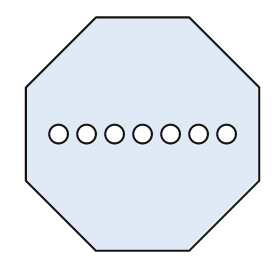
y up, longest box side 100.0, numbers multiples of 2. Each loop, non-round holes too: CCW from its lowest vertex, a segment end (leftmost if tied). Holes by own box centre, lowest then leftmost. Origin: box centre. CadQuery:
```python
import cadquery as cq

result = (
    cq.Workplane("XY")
    .moveTo(-20.0, -50.0)
    .lineTo(20.0, -50.0)
    .lineTo(50.0, -20.0)
    .lineTo(50.0, 20.0)
    .lineTo(20.0, 50.0)
    .lineTo(-20.0, 50.0)
    .lineTo(-50.0, 20.0)
    .lineTo(-50.0, -20.0)
    .close()
    .moveTo(-36.0, 0.0)
    .circle(4.0)
    .moveTo(-24.0, 0.0)
    .circle(4.0)
    .moveTo(-12.0, 0.0)
    .circle(4.0)
    .moveTo(0.0, 0.0)
    .circle(4.0)
    .moveTo(12.0, 0.0)
    .circle(4.0)
    .moveTo(24.0, 0.0)
    .circle(4.0)
    .moveTo(36.0, 0.0)
    .circle(4.0)
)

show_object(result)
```